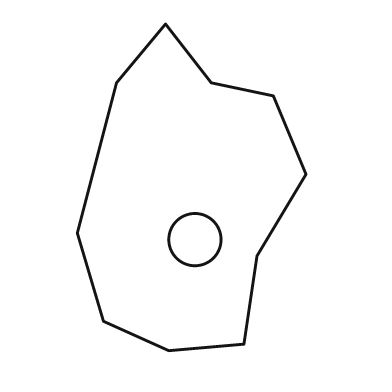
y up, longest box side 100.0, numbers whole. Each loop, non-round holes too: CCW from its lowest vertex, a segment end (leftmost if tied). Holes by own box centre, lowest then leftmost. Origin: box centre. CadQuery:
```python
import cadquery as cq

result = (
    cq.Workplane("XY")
    .moveTo(-7.0, -50.0)
    .lineTo(16.0, -48.0)
    .lineTo(20.0, -21.0)
    .lineTo(35.0, 4.0)
    .lineTo(25.0, 28.0)
    .lineTo(6.0, 32.0)
    .lineTo(-8.0, 50.0)
    .lineTo(-23.0, 32.0)
    .lineTo(-35.0, -14.0)
    .lineTo(-27.0, -41.0)
    .close()
    .moveTo(1.0, -16.0)
    .circle(8.0)
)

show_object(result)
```